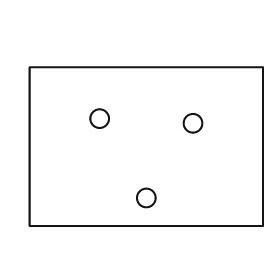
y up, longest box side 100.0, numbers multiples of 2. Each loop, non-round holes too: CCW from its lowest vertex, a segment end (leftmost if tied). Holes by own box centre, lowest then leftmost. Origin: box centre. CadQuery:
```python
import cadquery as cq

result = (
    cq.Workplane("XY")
    .moveTo(-50.0, -34.0)
    .lineTo(50.0, -34.0)
    .lineTo(50.0, 34.0)
    .lineTo(-50.0, 34.0)
    .close()
    .moveTo(0.0, -22.0)
    .circle(4.0)
    .moveTo(20.0, 10.0)
    .circle(4.0)
    .moveTo(-20.0, 12.0)
    .circle(4.0)
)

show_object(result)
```